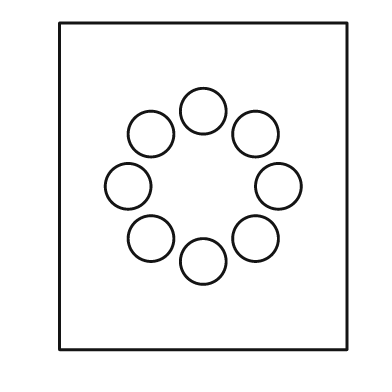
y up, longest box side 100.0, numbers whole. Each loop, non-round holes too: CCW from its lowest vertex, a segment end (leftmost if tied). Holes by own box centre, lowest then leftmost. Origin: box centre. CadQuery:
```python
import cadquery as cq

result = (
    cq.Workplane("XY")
    .moveTo(-44.0, -50.0)
    .lineTo(44.0, -50.0)
    .lineTo(44.0, 50.0)
    .lineTo(-44.0, 50.0)
    .close()
    .moveTo(0.0, -23.0)
    .circle(7.0)
    .moveTo(-16.0, -16.0)
    .circle(7.0)
    .moveTo(16.0, -16.0)
    .circle(7.0)
    .moveTo(-23.0, 0.0)
    .circle(7.0)
    .moveTo(23.0, 0.0)
    .circle(7.0)
    .moveTo(-16.0, 16.0)
    .circle(7.0)
    .moveTo(16.0, 16.0)
    .circle(7.0)
    .moveTo(0.0, 23.0)
    .circle(7.0)
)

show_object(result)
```